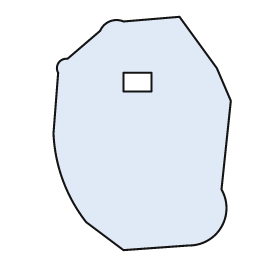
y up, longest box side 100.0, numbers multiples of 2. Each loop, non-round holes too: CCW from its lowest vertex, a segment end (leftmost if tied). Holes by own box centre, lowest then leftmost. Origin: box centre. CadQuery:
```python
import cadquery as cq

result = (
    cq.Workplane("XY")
    .moveTo(-8.0, -50.0)
    .lineTo(20.0, -48.0)
    .threePointArc((34.0, -40.0), (34.0, -24.0))
    .lineTo(38.0, 14.0)
    .lineTo(32.0, 28.0)
    .lineTo(16.0, 50.0)
    .lineTo(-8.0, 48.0)
    .threePointArc((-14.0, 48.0), (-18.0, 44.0))
    .lineTo(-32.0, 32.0)
    .threePointArc((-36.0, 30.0), (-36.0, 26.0))
    .lineTo(-38.0, 0.0)
    .threePointArc((-34.0, -20.0), (-24.0, -38.0))
    .close()
    .moveTo(-8.0, 18.0)
    .lineTo(4.0, 18.0)
    .lineTo(4.0, 26.0)
    .lineTo(-8.0, 26.0)
    .close()
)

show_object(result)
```